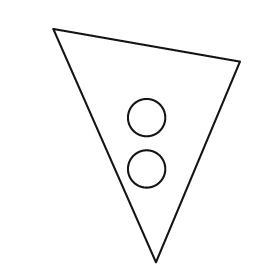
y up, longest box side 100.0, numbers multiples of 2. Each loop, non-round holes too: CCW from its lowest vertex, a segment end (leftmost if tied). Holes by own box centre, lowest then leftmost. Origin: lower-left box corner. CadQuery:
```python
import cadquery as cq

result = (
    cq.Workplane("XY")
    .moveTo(44.0, 0.0)
    .lineTo(80.0, 86.0)
    .lineTo(0.0, 100.0)
    .close()
    .moveTo(40.0, 40.0)
    .circle(8.0)
    .moveTo(40.0, 62.0)
    .circle(8.0)
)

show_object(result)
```